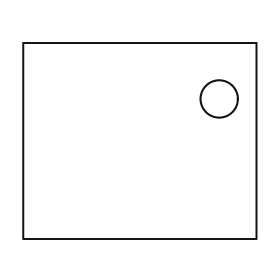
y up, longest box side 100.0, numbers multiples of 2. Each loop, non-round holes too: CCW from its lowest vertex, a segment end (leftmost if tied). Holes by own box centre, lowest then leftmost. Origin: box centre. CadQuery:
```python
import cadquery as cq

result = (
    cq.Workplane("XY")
    .moveTo(-50.0, -42.0)
    .lineTo(50.0, -42.0)
    .lineTo(50.0, 42.0)
    .lineTo(-50.0, 42.0)
    .close()
    .moveTo(34.0, 18.0)
    .circle(8.0)
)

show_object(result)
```